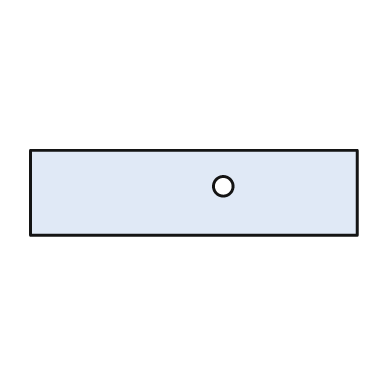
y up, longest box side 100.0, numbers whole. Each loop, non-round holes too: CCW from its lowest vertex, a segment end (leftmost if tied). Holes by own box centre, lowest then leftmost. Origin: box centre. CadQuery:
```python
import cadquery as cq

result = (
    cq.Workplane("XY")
    .moveTo(-50.0, -13.0)
    .lineTo(50.0, -13.0)
    .lineTo(50.0, 13.0)
    .lineTo(-50.0, 13.0)
    .close()
    .moveTo(9.0, 2.0)
    .circle(3.0)
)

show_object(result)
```